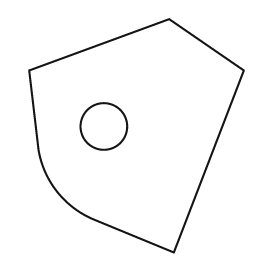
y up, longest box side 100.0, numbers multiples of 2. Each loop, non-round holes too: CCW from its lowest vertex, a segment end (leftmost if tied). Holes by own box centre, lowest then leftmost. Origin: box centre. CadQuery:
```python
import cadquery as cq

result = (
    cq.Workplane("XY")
    .moveTo(16.0, -50.0)
    .lineTo(46.0, 28.0)
    .lineTo(14.0, 50.0)
    .lineTo(-46.0, 28.0)
    .lineTo(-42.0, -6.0)
    .threePointArc((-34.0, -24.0), (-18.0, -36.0))
    .close()
    .moveTo(-14.0, 4.0)
    .circle(10.0)
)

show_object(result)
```